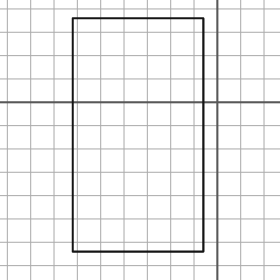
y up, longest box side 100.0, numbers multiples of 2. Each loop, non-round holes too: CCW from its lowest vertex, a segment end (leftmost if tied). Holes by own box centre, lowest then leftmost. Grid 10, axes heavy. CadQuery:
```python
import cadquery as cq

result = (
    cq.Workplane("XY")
    .moveTo(-62.0, -64.0)
    .lineTo(-6.0, -64.0)
    .lineTo(-6.0, 36.0)
    .lineTo(-62.0, 36.0)
    .close()
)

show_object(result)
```